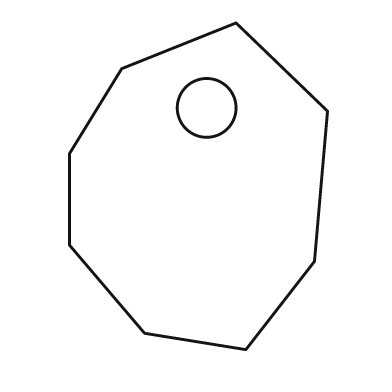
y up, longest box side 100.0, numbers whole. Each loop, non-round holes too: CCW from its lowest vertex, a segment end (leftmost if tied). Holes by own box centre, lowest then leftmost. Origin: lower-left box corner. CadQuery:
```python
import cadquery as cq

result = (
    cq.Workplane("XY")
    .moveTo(54.0, 0.0)
    .lineTo(75.0, 27.0)
    .lineTo(79.0, 73.0)
    .lineTo(51.0, 100.0)
    .lineTo(16.0, 86.0)
    .lineTo(0.0, 60.0)
    .lineTo(0.0, 32.0)
    .lineTo(23.0, 5.0)
    .close()
    .moveTo(42.0, 74.0)
    .circle(9.0)
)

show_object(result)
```